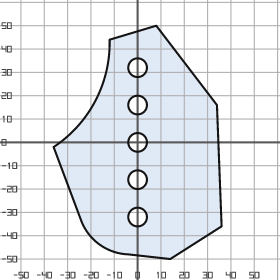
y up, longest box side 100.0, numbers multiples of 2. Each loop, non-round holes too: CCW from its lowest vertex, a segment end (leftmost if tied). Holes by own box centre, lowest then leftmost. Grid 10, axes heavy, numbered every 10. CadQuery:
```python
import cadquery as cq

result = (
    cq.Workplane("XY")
    .moveTo(14.0, -50.0)
    .lineTo(36.0, -36.0)
    .lineTo(34.0, 16.0)
    .lineTo(8.0, 50.0)
    .lineTo(-12.0, 44.0)
    .threePointArc((-18.0, 18.0), (-36.0, -2.0))
    .lineTo(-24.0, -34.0)
    .threePointArc((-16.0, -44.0), (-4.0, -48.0))
    .close()
    .moveTo(0.0, -32.0)
    .circle(4.0)
    .moveTo(0.0, -16.0)
    .circle(4.0)
    .moveTo(0.0, 0.0)
    .circle(4.0)
    .moveTo(0.0, 16.0)
    .circle(4.0)
    .moveTo(0.0, 32.0)
    .circle(4.0)
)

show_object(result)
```